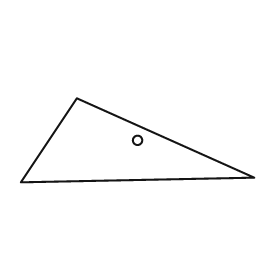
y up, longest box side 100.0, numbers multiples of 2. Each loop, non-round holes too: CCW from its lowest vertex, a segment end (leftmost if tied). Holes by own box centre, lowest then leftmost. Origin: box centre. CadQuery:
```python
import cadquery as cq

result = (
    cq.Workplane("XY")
    .moveTo(-50.0, -18.0)
    .lineTo(50.0, -16.0)
    .lineTo(-26.0, 18.0)
    .close()
    .moveTo(0.0, 0.0)
    .circle(2.0)
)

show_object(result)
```